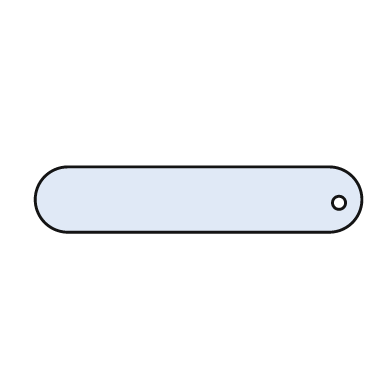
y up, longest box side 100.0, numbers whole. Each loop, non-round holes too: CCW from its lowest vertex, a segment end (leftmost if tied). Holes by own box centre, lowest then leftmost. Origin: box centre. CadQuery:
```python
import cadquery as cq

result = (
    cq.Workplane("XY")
    .moveTo(-40.0, -10.0)
    .lineTo(40.0, -10.0)
    .threePointArc((50.0, 0.0), (40.0, 10.0))
    .lineTo(-40.0, 10.0)
    .threePointArc((-50.0, 0.0), (-40.0, -10.0))
    .close()
    .moveTo(43.0, -1.0)
    .circle(2.0)
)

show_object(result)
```